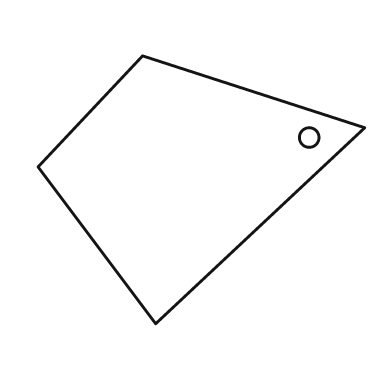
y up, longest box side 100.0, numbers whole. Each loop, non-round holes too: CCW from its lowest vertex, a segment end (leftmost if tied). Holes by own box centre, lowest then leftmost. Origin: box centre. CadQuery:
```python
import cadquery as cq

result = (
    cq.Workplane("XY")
    .moveTo(-14.0, -41.0)
    .lineTo(50.0, 19.0)
    .lineTo(-18.0, 41.0)
    .lineTo(-50.0, 7.0)
    .close()
    .moveTo(33.0, 16.0)
    .circle(3.0)
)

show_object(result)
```